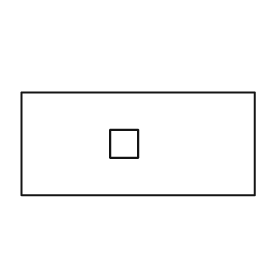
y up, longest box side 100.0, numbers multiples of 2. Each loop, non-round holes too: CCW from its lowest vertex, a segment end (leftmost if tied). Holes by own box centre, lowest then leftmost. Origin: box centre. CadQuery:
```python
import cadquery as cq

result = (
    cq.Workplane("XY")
    .moveTo(-50.0, -22.0)
    .lineTo(50.0, -22.0)
    .lineTo(50.0, 22.0)
    .lineTo(-50.0, 22.0)
    .close()
    .moveTo(-12.0, -6.0)
    .lineTo(0.0, -6.0)
    .lineTo(0.0, 6.0)
    .lineTo(-12.0, 6.0)
    .close()
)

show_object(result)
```